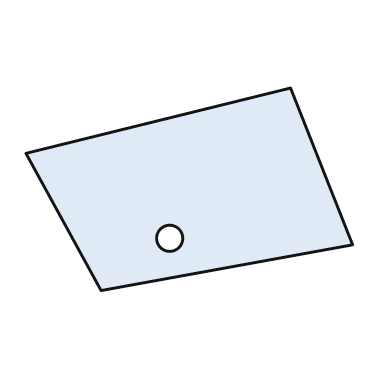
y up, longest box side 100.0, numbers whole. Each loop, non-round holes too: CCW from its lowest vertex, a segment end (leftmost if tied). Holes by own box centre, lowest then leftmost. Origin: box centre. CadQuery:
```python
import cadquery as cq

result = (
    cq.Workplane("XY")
    .moveTo(-27.0, -31.0)
    .lineTo(50.0, -17.0)
    .lineTo(31.0, 31.0)
    .lineTo(-50.0, 11.0)
    .close()
    .moveTo(-6.0, -15.0)
    .circle(4.0)
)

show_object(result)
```